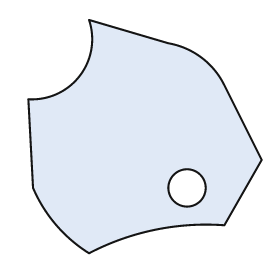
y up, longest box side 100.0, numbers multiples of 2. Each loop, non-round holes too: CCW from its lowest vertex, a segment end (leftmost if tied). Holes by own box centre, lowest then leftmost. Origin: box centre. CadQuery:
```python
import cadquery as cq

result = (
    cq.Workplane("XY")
    .moveTo(-24.0, -50.0)
    .threePointArc((4.0, -40.0), (34.0, -38.0))
    .lineTo(50.0, -10.0)
    .lineTo(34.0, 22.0)
    .threePointArc((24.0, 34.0), (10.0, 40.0))
    .lineTo(-24.0, 50.0)
    .threePointArc((-28.0, 26.0), (-50.0, 16.0))
    .lineTo(-48.0, -22.0)
    .threePointArc((-38.0, -38.0), (-24.0, -50.0))
    .close()
    .moveTo(18.0, -22.0)
    .circle(8.0)
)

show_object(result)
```